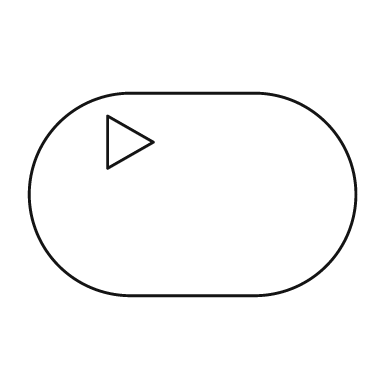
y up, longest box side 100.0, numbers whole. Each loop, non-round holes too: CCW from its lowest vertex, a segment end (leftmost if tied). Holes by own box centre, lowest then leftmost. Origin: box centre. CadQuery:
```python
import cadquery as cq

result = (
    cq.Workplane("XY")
    .moveTo(-19.0, -31.0)
    .lineTo(19.0, -31.0)
    .threePointArc((50.0, 0.0), (19.0, 31.0))
    .lineTo(-19.0, 31.0)
    .threePointArc((-50.0, 0.0), (-19.0, -31.0))
    .close()
    .moveTo(-26.0, 8.0)
    .lineTo(-12.0, 16.0)
    .lineTo(-26.0, 24.0)
    .close()
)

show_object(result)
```